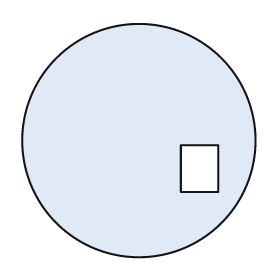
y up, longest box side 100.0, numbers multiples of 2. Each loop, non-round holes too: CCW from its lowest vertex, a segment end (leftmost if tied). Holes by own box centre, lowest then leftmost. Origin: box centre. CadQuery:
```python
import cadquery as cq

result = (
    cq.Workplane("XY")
    .moveTo(0.0, 0.0)
    .circle(50.0)
    .moveTo(18.0, -22.0)
    .lineTo(34.0, -22.0)
    .lineTo(34.0, -2.0)
    .lineTo(18.0, -2.0)
    .close()
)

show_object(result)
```